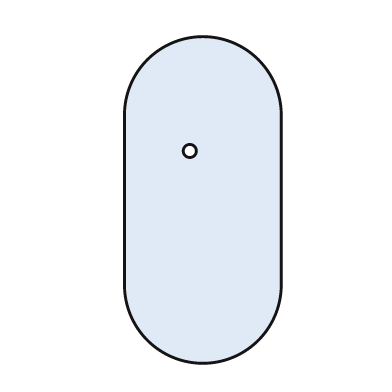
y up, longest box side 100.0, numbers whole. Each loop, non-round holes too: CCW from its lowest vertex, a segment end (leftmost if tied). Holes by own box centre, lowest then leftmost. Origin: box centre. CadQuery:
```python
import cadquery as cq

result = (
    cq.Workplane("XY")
    .moveTo(-24.0, -26.0)
    .threePointArc((0.0, -50.0), (24.0, -26.0))
    .lineTo(24.0, 26.0)
    .threePointArc((0.0, 50.0), (-24.0, 26.0))
    .close()
    .moveTo(-4.0, 15.0)
    .circle(2.0)
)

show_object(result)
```